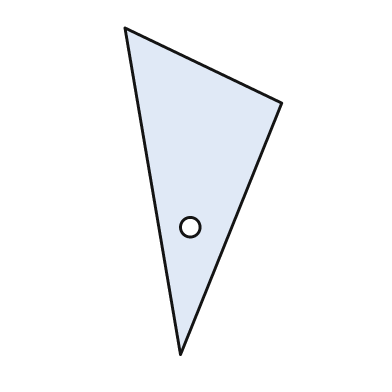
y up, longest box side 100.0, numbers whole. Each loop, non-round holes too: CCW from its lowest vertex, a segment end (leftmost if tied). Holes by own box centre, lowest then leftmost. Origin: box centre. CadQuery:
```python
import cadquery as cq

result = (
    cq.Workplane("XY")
    .moveTo(-7.0, -50.0)
    .lineTo(24.0, 27.0)
    .lineTo(-24.0, 50.0)
    .close()
    .moveTo(-4.0, -11.0)
    .circle(3.0)
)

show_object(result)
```